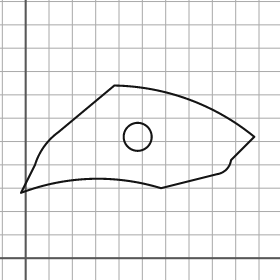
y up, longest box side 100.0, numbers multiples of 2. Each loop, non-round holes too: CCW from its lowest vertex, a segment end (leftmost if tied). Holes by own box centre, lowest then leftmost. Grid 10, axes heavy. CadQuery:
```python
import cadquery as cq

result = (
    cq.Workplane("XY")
    .moveTo(-2.0, 28.0)
    .threePointArc((28.0, 34.0), (58.0, 30.0))
    .lineTo(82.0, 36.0)
    .threePointArc((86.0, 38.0), (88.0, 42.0))
    .lineTo(98.0, 52.0)
    .threePointArc((70.0, 68.0), (38.0, 74.0))
    .lineTo(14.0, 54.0)
    .threePointArc((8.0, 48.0), (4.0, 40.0))
    .close()
    .moveTo(48.0, 52.0)
    .circle(6.0)
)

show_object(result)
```